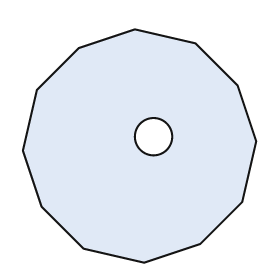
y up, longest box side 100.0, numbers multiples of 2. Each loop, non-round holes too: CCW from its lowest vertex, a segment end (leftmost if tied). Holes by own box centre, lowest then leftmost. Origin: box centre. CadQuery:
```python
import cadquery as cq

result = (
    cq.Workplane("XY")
    .moveTo(2.0, -50.0)
    .lineTo(26.0, -42.0)
    .lineTo(44.0, -24.0)
    .lineTo(50.0, 2.0)
    .lineTo(42.0, 26.0)
    .lineTo(24.0, 44.0)
    .lineTo(-2.0, 50.0)
    .lineTo(-26.0, 42.0)
    .lineTo(-44.0, 24.0)
    .lineTo(-50.0, -2.0)
    .lineTo(-42.0, -26.0)
    .lineTo(-24.0, -44.0)
    .close()
    .moveTo(6.0, 4.0)
    .circle(8.0)
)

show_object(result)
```